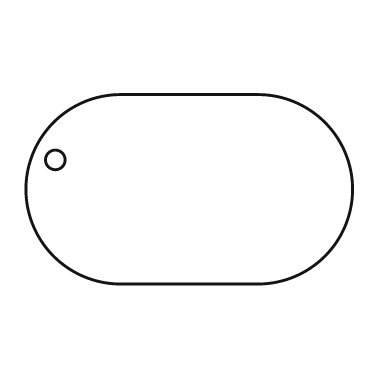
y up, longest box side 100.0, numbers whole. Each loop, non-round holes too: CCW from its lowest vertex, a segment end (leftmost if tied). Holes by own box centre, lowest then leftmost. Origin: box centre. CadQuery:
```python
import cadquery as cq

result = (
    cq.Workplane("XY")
    .moveTo(-21.0, -29.0)
    .lineTo(21.0, -29.0)
    .threePointArc((50.0, 0.0), (21.0, 29.0))
    .lineTo(-21.0, 29.0)
    .threePointArc((-50.0, 0.0), (-21.0, -29.0))
    .close()
    .moveTo(-41.0, 9.0)
    .circle(3.0)
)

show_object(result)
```